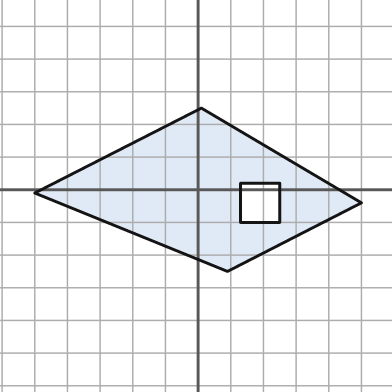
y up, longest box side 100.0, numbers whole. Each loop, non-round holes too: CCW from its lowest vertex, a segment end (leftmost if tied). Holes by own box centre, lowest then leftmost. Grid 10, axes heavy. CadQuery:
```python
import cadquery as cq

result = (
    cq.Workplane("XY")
    .moveTo(9.0, -25.0)
    .lineTo(50.0, -4.0)
    .lineTo(1.0, 25.0)
    .lineTo(-50.0, -1.0)
    .close()
    .moveTo(13.0, -10.0)
    .lineTo(25.0, -10.0)
    .lineTo(25.0, 2.0)
    .lineTo(13.0, 2.0)
    .close()
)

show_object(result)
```